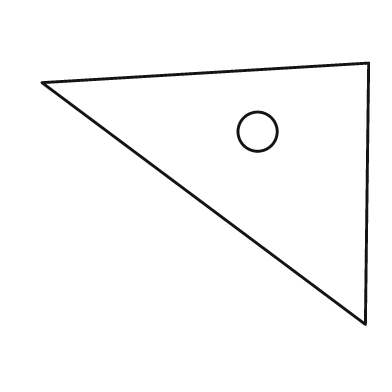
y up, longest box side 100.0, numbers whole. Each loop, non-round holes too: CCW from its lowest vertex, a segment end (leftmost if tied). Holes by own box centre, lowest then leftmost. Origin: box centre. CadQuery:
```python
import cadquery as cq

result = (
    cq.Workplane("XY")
    .moveTo(49.0, -40.0)
    .lineTo(50.0, 40.0)
    .lineTo(-50.0, 34.0)
    .close()
    .moveTo(16.0, 19.0)
    .circle(6.0)
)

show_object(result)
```